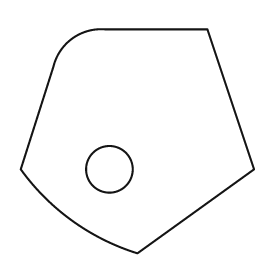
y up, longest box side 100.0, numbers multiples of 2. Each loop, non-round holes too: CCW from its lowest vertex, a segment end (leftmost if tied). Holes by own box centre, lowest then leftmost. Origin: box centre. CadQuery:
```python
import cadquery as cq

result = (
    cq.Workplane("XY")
    .moveTo(0.0, -48.0)
    .lineTo(50.0, -12.0)
    .lineTo(30.0, 48.0)
    .lineTo(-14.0, 48.0)
    .threePointArc((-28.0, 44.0), (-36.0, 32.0))
    .lineTo(-50.0, -12.0)
    .threePointArc((-28.0, -34.0), (0.0, -48.0))
    .close()
    .moveTo(-12.0, -12.0)
    .circle(10.0)
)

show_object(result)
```